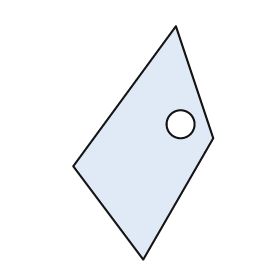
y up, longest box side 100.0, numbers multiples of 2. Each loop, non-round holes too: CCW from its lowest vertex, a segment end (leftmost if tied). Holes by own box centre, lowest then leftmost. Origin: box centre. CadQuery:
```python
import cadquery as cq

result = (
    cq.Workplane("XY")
    .moveTo(0.0, -50.0)
    .lineTo(30.0, 2.0)
    .lineTo(14.0, 50.0)
    .lineTo(-30.0, -10.0)
    .close()
    .moveTo(16.0, 8.0)
    .circle(6.0)
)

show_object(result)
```